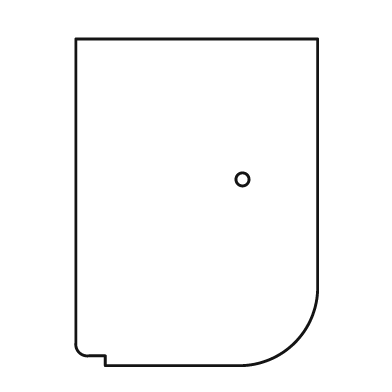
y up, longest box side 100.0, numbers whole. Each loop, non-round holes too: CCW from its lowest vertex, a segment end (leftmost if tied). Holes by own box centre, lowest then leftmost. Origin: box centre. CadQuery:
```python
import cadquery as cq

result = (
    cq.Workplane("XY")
    .moveTo(-28.0, -50.0)
    .lineTo(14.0, -50.0)
    .threePointArc((30.0, -43.0), (37.0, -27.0))
    .lineTo(37.0, 50.0)
    .lineTo(-37.0, 50.0)
    .lineTo(-37.0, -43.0)
    .threePointArc((-36.0, -46.0), (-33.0, -47.0))
    .lineTo(-28.0, -47.0)
    .close()
    .moveTo(14.0, 7.0)
    .circle(2.0)
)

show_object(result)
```